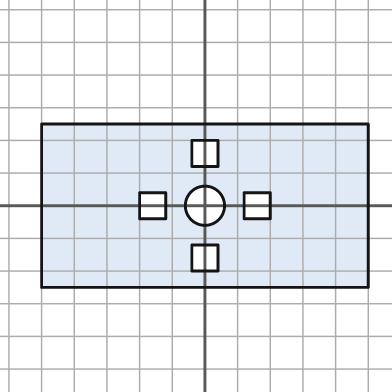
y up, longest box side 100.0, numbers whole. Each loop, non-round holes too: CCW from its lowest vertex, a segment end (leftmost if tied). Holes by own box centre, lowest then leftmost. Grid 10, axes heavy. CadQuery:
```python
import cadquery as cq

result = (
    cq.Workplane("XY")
    .moveTo(-50.0, -25.0)
    .lineTo(50.0, -25.0)
    .lineTo(50.0, 25.0)
    .lineTo(-50.0, 25.0)
    .close()
    .moveTo(-4.0, -20.0)
    .lineTo(4.0, -20.0)
    .lineTo(4.0, -12.0)
    .lineTo(-4.0, -12.0)
    .close()
    .moveTo(-20.0, -4.0)
    .lineTo(-12.0, -4.0)
    .lineTo(-12.0, 4.0)
    .lineTo(-20.0, 4.0)
    .close()
    .moveTo(0.0, 0.0)
    .circle(6.0)
    .moveTo(12.0, -4.0)
    .lineTo(20.0, -4.0)
    .lineTo(20.0, 4.0)
    .lineTo(12.0, 4.0)
    .close()
    .moveTo(-4.0, 12.0)
    .lineTo(4.0, 12.0)
    .lineTo(4.0, 20.0)
    .lineTo(-4.0, 20.0)
    .close()
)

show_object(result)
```